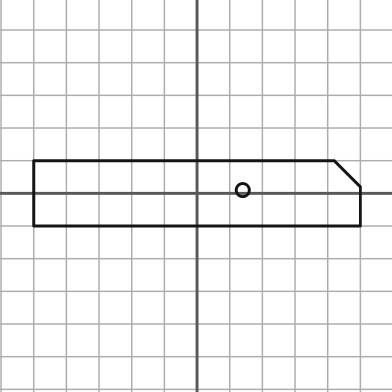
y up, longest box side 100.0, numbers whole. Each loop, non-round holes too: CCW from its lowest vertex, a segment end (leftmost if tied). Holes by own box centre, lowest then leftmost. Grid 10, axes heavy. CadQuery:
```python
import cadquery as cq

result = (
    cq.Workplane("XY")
    .moveTo(-50.0, -10.0)
    .lineTo(50.0, -10.0)
    .lineTo(50.0, 2.0)
    .lineTo(42.0, 10.0)
    .lineTo(-50.0, 10.0)
    .close()
    .moveTo(14.0, 1.0)
    .circle(2.0)
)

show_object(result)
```